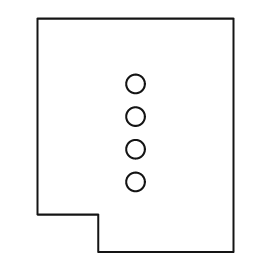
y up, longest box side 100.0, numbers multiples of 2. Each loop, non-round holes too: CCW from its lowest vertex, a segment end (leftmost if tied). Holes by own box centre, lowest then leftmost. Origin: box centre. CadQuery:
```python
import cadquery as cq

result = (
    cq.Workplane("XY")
    .moveTo(-16.0, -50.0)
    .lineTo(42.0, -50.0)
    .lineTo(42.0, 50.0)
    .lineTo(-42.0, 50.0)
    .lineTo(-42.0, -34.0)
    .lineTo(-16.0, -34.0)
    .close()
    .moveTo(0.0, -20.0)
    .circle(4.0)
    .moveTo(0.0, -6.0)
    .circle(4.0)
    .moveTo(0.0, 8.0)
    .circle(4.0)
    .moveTo(0.0, 22.0)
    .circle(4.0)
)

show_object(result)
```